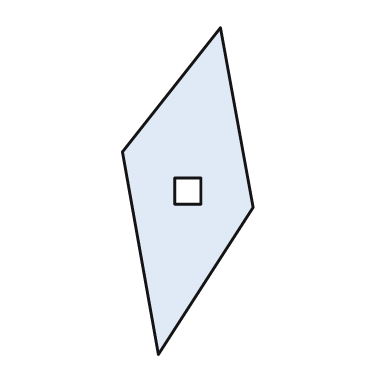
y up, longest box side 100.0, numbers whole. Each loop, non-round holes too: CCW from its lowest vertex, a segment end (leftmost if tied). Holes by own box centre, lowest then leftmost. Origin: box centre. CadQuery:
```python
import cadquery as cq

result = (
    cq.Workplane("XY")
    .moveTo(-9.0, -50.0)
    .lineTo(20.0, -5.0)
    .lineTo(10.0, 50.0)
    .lineTo(-20.0, 12.0)
    .close()
    .moveTo(-4.0, -4.0)
    .lineTo(4.0, -4.0)
    .lineTo(4.0, 4.0)
    .lineTo(-4.0, 4.0)
    .close()
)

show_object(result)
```